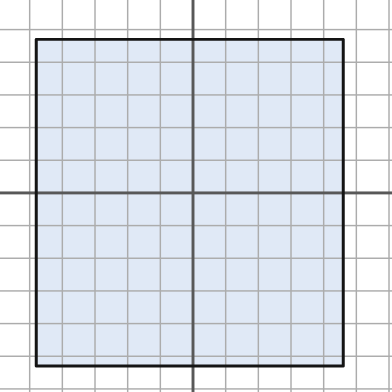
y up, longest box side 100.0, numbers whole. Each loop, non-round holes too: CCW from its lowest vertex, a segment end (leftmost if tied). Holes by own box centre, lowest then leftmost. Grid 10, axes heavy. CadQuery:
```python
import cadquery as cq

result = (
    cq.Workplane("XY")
    .moveTo(-48.0, -53.0)
    .lineTo(46.0, -53.0)
    .lineTo(46.0, 47.0)
    .lineTo(-48.0, 47.0)
    .close()
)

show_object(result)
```